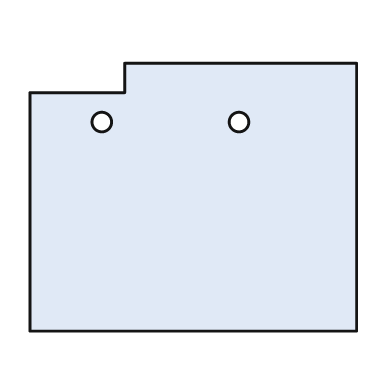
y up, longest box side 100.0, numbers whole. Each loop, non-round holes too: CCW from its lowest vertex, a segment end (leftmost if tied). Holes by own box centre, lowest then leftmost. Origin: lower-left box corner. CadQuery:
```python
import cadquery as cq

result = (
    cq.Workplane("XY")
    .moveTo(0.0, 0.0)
    .lineTo(100.0, 0.0)
    .lineTo(100.0, 82.0)
    .lineTo(29.0, 82.0)
    .lineTo(29.0, 73.0)
    .lineTo(0.0, 73.0)
    .close()
    .moveTo(22.0, 64.0)
    .circle(3.0)
    .moveTo(64.0, 64.0)
    .circle(3.0)
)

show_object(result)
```